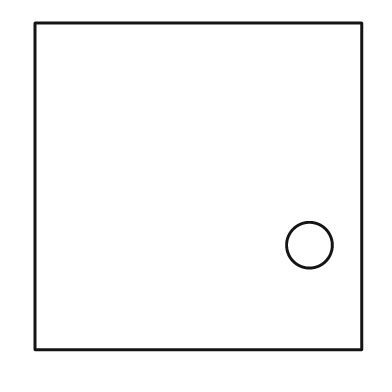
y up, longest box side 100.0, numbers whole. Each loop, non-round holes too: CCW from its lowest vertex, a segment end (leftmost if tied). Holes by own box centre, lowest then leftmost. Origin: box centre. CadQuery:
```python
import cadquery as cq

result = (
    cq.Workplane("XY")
    .moveTo(-50.0, -50.0)
    .lineTo(50.0, -50.0)
    .lineTo(50.0, 50.0)
    .lineTo(-50.0, 50.0)
    .close()
    .moveTo(34.0, -18.0)
    .circle(7.0)
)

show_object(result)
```